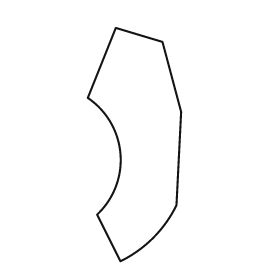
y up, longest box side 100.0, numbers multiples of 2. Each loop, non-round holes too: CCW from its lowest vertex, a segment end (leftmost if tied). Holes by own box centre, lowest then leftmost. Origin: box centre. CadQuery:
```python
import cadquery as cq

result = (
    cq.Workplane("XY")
    .moveTo(-6.0, -50.0)
    .threePointArc((8.0, -40.0), (18.0, -26.0))
    .lineTo(20.0, 14.0)
    .lineTo(12.0, 44.0)
    .lineTo(-8.0, 50.0)
    .lineTo(-20.0, 20.0)
    .threePointArc((-6.0, -4.0), (-16.0, -30.0))
    .close()
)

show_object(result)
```